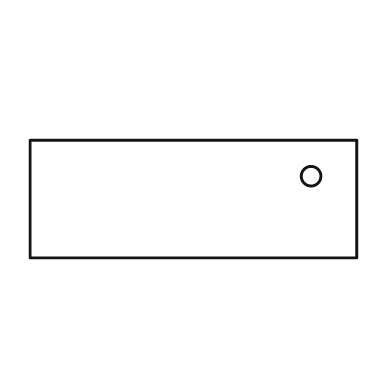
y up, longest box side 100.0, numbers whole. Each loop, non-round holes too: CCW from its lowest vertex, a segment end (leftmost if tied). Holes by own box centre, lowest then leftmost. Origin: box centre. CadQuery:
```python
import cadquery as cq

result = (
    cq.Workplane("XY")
    .moveTo(-50.0, -18.0)
    .lineTo(50.0, -18.0)
    .lineTo(50.0, 18.0)
    .lineTo(-50.0, 18.0)
    .close()
    .moveTo(36.0, 7.0)
    .circle(3.0)
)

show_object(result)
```